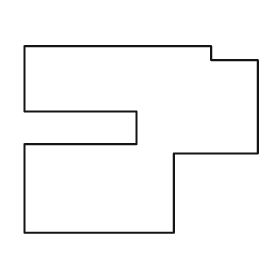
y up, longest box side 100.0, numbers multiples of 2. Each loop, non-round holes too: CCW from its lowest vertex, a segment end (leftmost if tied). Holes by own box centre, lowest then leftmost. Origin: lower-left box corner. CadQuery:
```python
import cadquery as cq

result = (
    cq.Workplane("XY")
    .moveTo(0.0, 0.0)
    .lineTo(64.0, 0.0)
    .lineTo(64.0, 34.0)
    .lineTo(100.0, 34.0)
    .lineTo(100.0, 74.0)
    .lineTo(80.0, 74.0)
    .lineTo(80.0, 80.0)
    .lineTo(0.0, 80.0)
    .lineTo(0.0, 52.0)
    .lineTo(48.0, 52.0)
    .lineTo(48.0, 38.0)
    .lineTo(0.0, 38.0)
    .close()
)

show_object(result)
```